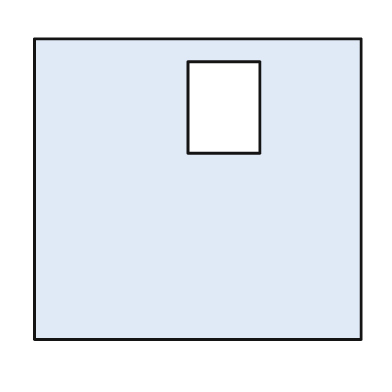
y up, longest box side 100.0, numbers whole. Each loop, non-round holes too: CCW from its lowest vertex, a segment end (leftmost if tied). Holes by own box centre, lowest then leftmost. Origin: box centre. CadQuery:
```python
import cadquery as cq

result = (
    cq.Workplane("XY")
    .moveTo(-50.0, -46.0)
    .lineTo(50.0, -46.0)
    .lineTo(50.0, 46.0)
    .lineTo(-50.0, 46.0)
    .close()
    .moveTo(-3.0, 11.0)
    .lineTo(19.0, 11.0)
    .lineTo(19.0, 39.0)
    .lineTo(-3.0, 39.0)
    .close()
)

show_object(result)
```